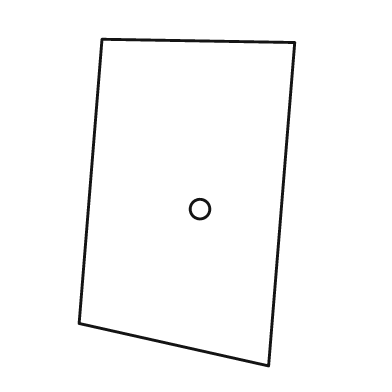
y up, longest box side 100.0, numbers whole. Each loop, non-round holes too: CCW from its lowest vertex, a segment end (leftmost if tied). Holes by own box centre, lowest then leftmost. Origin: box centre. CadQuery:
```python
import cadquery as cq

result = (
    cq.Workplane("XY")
    .moveTo(25.0, -50.0)
    .lineTo(33.0, 49.0)
    .lineTo(-26.0, 50.0)
    .lineTo(-33.0, -37.0)
    .close()
    .moveTo(4.0, -2.0)
    .circle(3.0)
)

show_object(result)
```